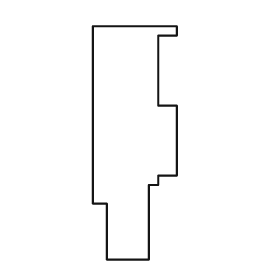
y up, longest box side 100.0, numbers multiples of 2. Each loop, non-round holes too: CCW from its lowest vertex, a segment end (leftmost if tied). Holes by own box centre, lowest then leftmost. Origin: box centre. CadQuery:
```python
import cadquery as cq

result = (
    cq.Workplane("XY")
    .moveTo(-12.0, -50.0)
    .lineTo(6.0, -50.0)
    .lineTo(6.0, -18.0)
    .lineTo(10.0, -18.0)
    .lineTo(10.0, -14.0)
    .lineTo(18.0, -14.0)
    .lineTo(18.0, 16.0)
    .lineTo(10.0, 16.0)
    .lineTo(10.0, 46.0)
    .lineTo(18.0, 46.0)
    .lineTo(18.0, 50.0)
    .lineTo(-18.0, 50.0)
    .lineTo(-18.0, -26.0)
    .lineTo(-12.0, -26.0)
    .close()
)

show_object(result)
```